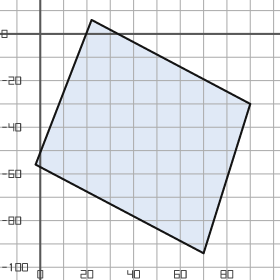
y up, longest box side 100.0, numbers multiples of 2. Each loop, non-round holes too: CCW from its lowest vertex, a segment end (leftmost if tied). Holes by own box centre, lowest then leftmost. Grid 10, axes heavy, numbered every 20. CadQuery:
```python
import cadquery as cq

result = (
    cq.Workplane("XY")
    .moveTo(70.0, -94.0)
    .lineTo(90.0, -30.0)
    .lineTo(22.0, 6.0)
    .lineTo(-2.0, -56.0)
    .close()
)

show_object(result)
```